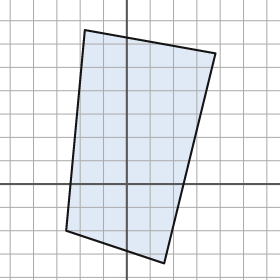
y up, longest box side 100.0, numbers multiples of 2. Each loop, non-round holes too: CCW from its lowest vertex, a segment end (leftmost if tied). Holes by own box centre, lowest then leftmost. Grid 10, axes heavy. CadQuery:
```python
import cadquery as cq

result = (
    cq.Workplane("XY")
    .moveTo(16.0, -34.0)
    .lineTo(38.0, 56.0)
    .lineTo(-18.0, 66.0)
    .lineTo(-26.0, -20.0)
    .close()
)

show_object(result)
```